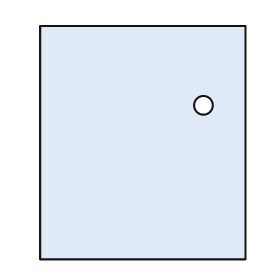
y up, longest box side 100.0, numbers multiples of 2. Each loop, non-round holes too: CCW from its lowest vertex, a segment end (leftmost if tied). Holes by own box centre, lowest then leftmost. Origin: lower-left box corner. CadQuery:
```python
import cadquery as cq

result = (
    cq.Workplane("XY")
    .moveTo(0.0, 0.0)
    .lineTo(88.0, 0.0)
    .lineTo(88.0, 100.0)
    .lineTo(0.0, 100.0)
    .close()
    .moveTo(70.0, 66.0)
    .circle(4.0)
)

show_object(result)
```